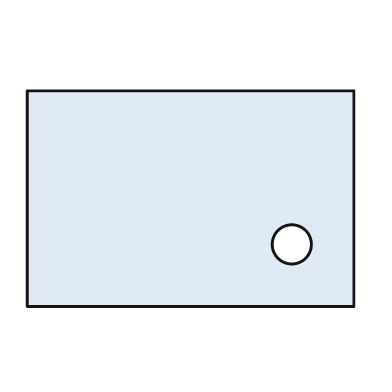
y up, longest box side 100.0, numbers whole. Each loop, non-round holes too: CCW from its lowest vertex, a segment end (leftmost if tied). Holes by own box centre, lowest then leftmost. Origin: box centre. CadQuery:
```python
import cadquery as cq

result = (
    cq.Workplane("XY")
    .moveTo(-50.0, -33.0)
    .lineTo(50.0, -33.0)
    .lineTo(50.0, 33.0)
    .lineTo(-50.0, 33.0)
    .close()
    .moveTo(31.0, -14.0)
    .circle(6.0)
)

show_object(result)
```